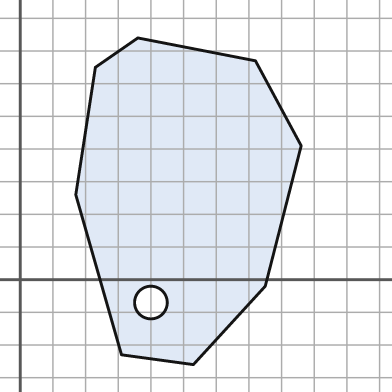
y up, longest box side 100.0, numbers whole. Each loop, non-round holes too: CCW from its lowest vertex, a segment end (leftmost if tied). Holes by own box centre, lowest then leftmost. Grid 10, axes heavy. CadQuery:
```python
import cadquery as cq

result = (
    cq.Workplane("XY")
    .moveTo(53.0, -26.0)
    .lineTo(75.0, -2.0)
    .lineTo(86.0, 41.0)
    .lineTo(72.0, 67.0)
    .lineTo(36.0, 74.0)
    .lineTo(23.0, 65.0)
    .lineTo(17.0, 26.0)
    .lineTo(31.0, -23.0)
    .close()
    .moveTo(40.0, -7.0)
    .circle(5.0)
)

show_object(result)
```